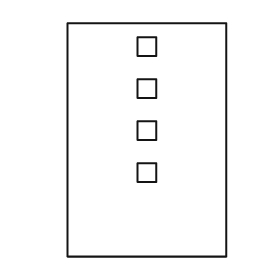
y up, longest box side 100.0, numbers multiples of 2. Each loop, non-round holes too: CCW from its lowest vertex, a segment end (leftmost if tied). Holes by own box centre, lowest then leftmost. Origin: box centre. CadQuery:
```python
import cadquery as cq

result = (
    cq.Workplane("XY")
    .moveTo(-34.0, -50.0)
    .lineTo(34.0, -50.0)
    .lineTo(34.0, 50.0)
    .lineTo(-34.0, 50.0)
    .close()
    .moveTo(-4.0, -18.0)
    .lineTo(4.0, -18.0)
    .lineTo(4.0, -10.0)
    .lineTo(-4.0, -10.0)
    .close()
    .moveTo(-4.0, 0.0)
    .lineTo(4.0, 0.0)
    .lineTo(4.0, 8.0)
    .lineTo(-4.0, 8.0)
    .close()
    .moveTo(-4.0, 18.0)
    .lineTo(4.0, 18.0)
    .lineTo(4.0, 26.0)
    .lineTo(-4.0, 26.0)
    .close()
    .moveTo(-4.0, 36.0)
    .lineTo(4.0, 36.0)
    .lineTo(4.0, 44.0)
    .lineTo(-4.0, 44.0)
    .close()
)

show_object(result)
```